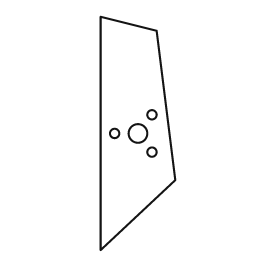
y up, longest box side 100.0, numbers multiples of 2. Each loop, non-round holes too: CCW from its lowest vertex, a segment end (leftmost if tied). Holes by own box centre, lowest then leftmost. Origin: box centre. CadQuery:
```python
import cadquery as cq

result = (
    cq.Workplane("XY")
    .moveTo(-16.0, -50.0)
    .lineTo(16.0, -20.0)
    .lineTo(8.0, 44.0)
    .lineTo(-16.0, 50.0)
    .close()
    .moveTo(6.0, -8.0)
    .circle(2.0)
    .moveTo(-10.0, 0.0)
    .circle(2.0)
    .moveTo(0.0, 0.0)
    .circle(4.0)
    .moveTo(6.0, 8.0)
    .circle(2.0)
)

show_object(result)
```